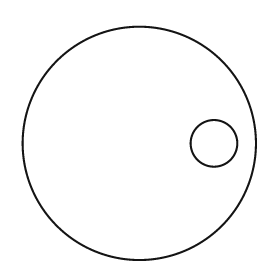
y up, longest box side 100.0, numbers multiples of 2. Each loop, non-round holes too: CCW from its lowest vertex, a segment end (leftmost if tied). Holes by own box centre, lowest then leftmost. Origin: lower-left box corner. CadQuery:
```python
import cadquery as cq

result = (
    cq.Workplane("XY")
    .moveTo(50.0, 50.0)
    .circle(50.0)
    .moveTo(82.0, 50.0)
    .circle(10.0)
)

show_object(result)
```